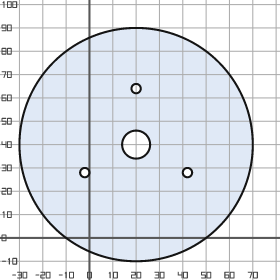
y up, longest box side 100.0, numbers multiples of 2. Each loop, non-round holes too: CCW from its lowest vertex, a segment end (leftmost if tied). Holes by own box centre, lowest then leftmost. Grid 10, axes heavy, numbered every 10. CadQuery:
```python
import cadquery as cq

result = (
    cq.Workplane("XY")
    .moveTo(20.0, 40.0)
    .circle(50.0)
    .moveTo(-2.0, 28.0)
    .circle(2.0)
    .moveTo(42.0, 28.0)
    .circle(2.0)
    .moveTo(20.0, 40.0)
    .circle(6.0)
    .moveTo(20.0, 64.0)
    .circle(2.0)
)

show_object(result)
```